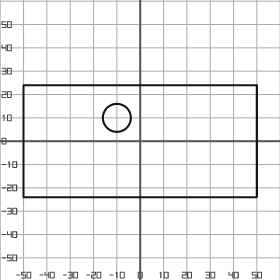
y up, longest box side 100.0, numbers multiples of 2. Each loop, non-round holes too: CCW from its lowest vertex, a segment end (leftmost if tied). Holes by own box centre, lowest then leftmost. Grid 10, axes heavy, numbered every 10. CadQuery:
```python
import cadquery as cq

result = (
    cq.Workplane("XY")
    .moveTo(-50.0, -24.0)
    .lineTo(50.0, -24.0)
    .lineTo(50.0, 24.0)
    .lineTo(-50.0, 24.0)
    .close()
    .moveTo(-10.0, 10.0)
    .circle(6.0)
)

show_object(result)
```